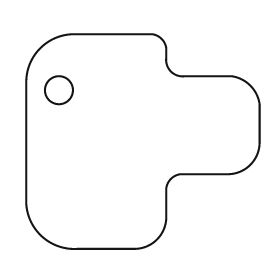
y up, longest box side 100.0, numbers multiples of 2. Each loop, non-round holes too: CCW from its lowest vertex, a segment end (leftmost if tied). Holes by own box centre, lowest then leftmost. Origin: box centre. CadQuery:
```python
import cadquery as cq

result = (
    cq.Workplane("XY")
    .moveTo(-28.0, -46.0)
    .lineTo(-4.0, -46.0)
    .threePointArc((6.0, -42.0), (10.0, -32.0))
    .lineTo(10.0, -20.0)
    .threePointArc((12.0, -16.0), (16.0, -14.0))
    .lineTo(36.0, -14.0)
    .threePointArc((46.0, -10.0), (50.0, 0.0))
    .lineTo(50.0, 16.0)
    .threePointArc((46.0, 24.0), (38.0, 28.0))
    .lineTo(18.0, 28.0)
    .threePointArc((12.0, 30.0), (10.0, 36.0))
    .lineTo(10.0, 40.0)
    .threePointArc((8.0, 44.0), (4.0, 46.0))
    .lineTo(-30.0, 46.0)
    .threePointArc((-44.0, 40.0), (-50.0, 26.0))
    .lineTo(-50.0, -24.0)
    .threePointArc((-44.0, -40.0), (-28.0, -46.0))
    .close()
    .moveTo(-36.0, 22.0)
    .circle(6.0)
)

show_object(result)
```